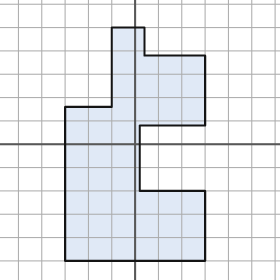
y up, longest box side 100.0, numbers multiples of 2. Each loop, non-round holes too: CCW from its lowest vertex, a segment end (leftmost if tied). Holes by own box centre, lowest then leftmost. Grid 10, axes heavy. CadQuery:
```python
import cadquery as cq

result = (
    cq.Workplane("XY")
    .moveTo(-30.0, -50.0)
    .lineTo(30.0, -50.0)
    .lineTo(30.0, -20.0)
    .lineTo(2.0, -20.0)
    .lineTo(2.0, 8.0)
    .lineTo(30.0, 8.0)
    .lineTo(30.0, 38.0)
    .lineTo(4.0, 38.0)
    .lineTo(4.0, 50.0)
    .lineTo(-10.0, 50.0)
    .lineTo(-10.0, 16.0)
    .lineTo(-30.0, 16.0)
    .close()
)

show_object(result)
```